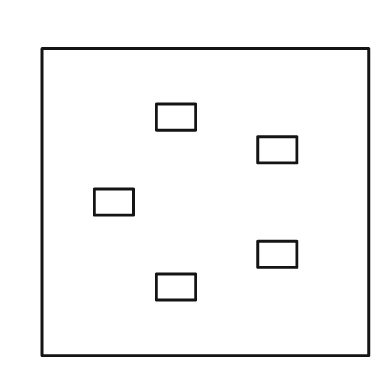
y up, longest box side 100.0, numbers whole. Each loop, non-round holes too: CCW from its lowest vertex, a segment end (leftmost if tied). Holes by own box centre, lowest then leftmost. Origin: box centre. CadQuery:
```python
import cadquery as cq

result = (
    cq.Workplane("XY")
    .moveTo(-50.0, -47.0)
    .lineTo(50.0, -47.0)
    .lineTo(50.0, 47.0)
    .lineTo(-50.0, 47.0)
    .close()
    .moveTo(-15.0, -30.0)
    .lineTo(-3.0, -30.0)
    .lineTo(-3.0, -22.0)
    .lineTo(-15.0, -22.0)
    .close()
    .moveTo(16.0, -20.0)
    .lineTo(28.0, -20.0)
    .lineTo(28.0, -12.0)
    .lineTo(16.0, -12.0)
    .close()
    .moveTo(-34.0, -4.0)
    .lineTo(-22.0, -4.0)
    .lineTo(-22.0, 4.0)
    .lineTo(-34.0, 4.0)
    .close()
    .moveTo(16.0, 12.0)
    .lineTo(28.0, 12.0)
    .lineTo(28.0, 20.0)
    .lineTo(16.0, 20.0)
    .close()
    .moveTo(-15.0, 22.0)
    .lineTo(-3.0, 22.0)
    .lineTo(-3.0, 30.0)
    .lineTo(-15.0, 30.0)
    .close()
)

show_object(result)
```